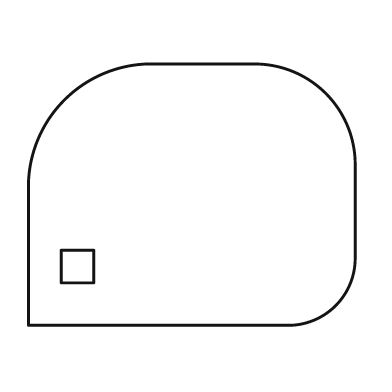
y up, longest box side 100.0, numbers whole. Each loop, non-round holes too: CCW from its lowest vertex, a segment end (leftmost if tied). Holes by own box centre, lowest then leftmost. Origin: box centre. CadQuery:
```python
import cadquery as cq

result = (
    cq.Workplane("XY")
    .moveTo(-50.0, -40.0)
    .lineTo(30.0, -40.0)
    .threePointArc((44.0, -34.0), (50.0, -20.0))
    .lineTo(50.0, 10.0)
    .threePointArc((41.0, 31.0), (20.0, 40.0))
    .lineTo(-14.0, 40.0)
    .threePointArc((-39.0, 29.0), (-50.0, 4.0))
    .close()
    .moveTo(-40.0, -27.0)
    .lineTo(-30.0, -27.0)
    .lineTo(-30.0, -17.0)
    .lineTo(-40.0, -17.0)
    .close()
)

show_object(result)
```